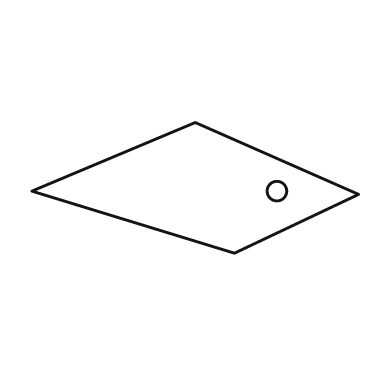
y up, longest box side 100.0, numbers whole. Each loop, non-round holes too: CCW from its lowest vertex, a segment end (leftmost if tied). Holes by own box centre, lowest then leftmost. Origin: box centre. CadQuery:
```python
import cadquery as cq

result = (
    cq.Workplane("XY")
    .moveTo(12.0, -20.0)
    .lineTo(50.0, -2.0)
    .lineTo(0.0, 20.0)
    .lineTo(-50.0, -1.0)
    .close()
    .moveTo(25.0, -1.0)
    .circle(3.0)
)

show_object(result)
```